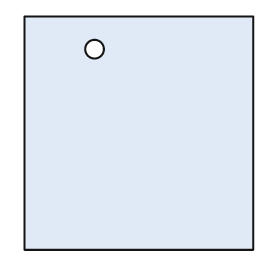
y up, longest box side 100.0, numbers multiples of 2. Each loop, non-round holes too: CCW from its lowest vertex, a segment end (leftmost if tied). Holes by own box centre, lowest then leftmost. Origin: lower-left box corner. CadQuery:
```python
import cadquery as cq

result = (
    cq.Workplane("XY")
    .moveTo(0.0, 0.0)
    .lineTo(98.0, 0.0)
    .lineTo(98.0, 100.0)
    .lineTo(0.0, 100.0)
    .close()
    .moveTo(30.0, 86.0)
    .circle(4.0)
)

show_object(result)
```